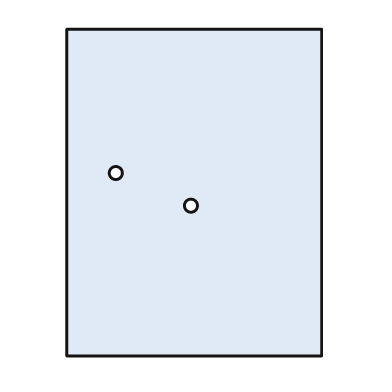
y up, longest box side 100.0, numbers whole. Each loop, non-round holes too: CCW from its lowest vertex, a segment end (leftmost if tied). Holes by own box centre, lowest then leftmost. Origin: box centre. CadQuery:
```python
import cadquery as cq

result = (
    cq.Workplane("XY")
    .moveTo(-39.0, -50.0)
    .lineTo(39.0, -50.0)
    .lineTo(39.0, 50.0)
    .lineTo(-39.0, 50.0)
    .close()
    .moveTo(-1.0, -4.0)
    .circle(2.0)
    .moveTo(-24.0, 6.0)
    .circle(2.0)
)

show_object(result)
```